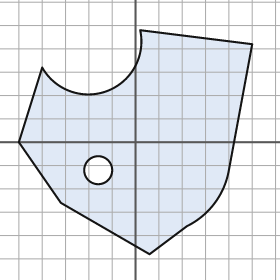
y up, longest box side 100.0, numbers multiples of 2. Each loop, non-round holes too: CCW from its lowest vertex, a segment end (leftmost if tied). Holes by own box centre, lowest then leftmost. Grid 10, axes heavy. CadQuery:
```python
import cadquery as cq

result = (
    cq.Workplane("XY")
    .moveTo(6.0, -48.0)
    .lineTo(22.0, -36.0)
    .threePointArc((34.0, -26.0), (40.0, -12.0))
    .lineTo(50.0, 42.0)
    .lineTo(2.0, 48.0)
    .threePointArc((-12.0, 22.0), (-40.0, 32.0))
    .lineTo(-50.0, 0.0)
    .lineTo(-32.0, -26.0)
    .close()
    .moveTo(-16.0, -12.0)
    .circle(6.0)
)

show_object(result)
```